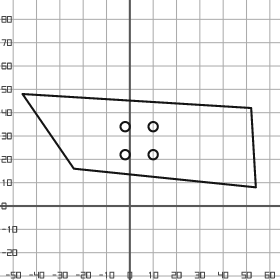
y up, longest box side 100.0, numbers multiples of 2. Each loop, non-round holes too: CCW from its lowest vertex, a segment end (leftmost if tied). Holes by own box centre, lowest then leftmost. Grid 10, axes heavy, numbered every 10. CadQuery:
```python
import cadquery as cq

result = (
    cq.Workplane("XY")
    .moveTo(54.0, 8.0)
    .lineTo(52.0, 42.0)
    .lineTo(-46.0, 48.0)
    .lineTo(-24.0, 16.0)
    .close()
    .moveTo(-2.0, 22.0)
    .circle(2.0)
    .moveTo(10.0, 22.0)
    .circle(2.0)
    .moveTo(-2.0, 34.0)
    .circle(2.0)
    .moveTo(10.0, 34.0)
    .circle(2.0)
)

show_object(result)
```